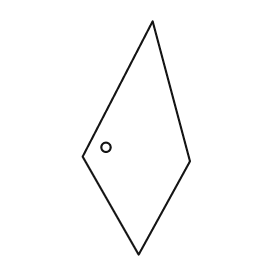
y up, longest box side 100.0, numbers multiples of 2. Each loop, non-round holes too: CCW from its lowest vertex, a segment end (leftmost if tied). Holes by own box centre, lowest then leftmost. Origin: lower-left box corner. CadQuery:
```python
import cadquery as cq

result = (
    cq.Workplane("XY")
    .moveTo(24.0, 0.0)
    .lineTo(46.0, 40.0)
    .lineTo(30.0, 100.0)
    .lineTo(0.0, 42.0)
    .close()
    .moveTo(10.0, 46.0)
    .circle(2.0)
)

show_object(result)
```